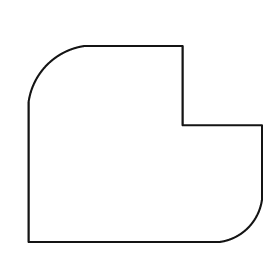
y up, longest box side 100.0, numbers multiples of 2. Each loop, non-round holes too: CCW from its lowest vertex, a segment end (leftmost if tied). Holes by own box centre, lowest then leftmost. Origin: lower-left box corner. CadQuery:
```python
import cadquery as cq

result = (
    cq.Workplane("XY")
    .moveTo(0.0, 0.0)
    .lineTo(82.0, 0.0)
    .threePointArc((94.0, 6.0), (100.0, 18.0))
    .lineTo(100.0, 50.0)
    .lineTo(66.0, 50.0)
    .lineTo(66.0, 84.0)
    .lineTo(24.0, 84.0)
    .threePointArc((8.0, 76.0), (0.0, 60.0))
    .close()
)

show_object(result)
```